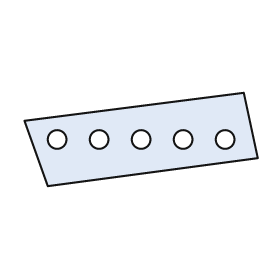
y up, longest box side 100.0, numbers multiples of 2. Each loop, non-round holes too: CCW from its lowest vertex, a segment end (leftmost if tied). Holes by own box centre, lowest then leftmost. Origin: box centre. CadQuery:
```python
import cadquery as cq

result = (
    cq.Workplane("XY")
    .moveTo(-40.0, -20.0)
    .lineTo(50.0, -8.0)
    .lineTo(44.0, 20.0)
    .lineTo(-50.0, 8.0)
    .close()
    .moveTo(-36.0, 0.0)
    .circle(4.0)
    .moveTo(-18.0, 0.0)
    .circle(4.0)
    .moveTo(0.0, 0.0)
    .circle(4.0)
    .moveTo(18.0, 0.0)
    .circle(4.0)
    .moveTo(36.0, 0.0)
    .circle(4.0)
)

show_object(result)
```